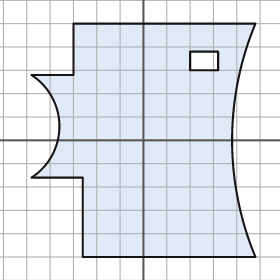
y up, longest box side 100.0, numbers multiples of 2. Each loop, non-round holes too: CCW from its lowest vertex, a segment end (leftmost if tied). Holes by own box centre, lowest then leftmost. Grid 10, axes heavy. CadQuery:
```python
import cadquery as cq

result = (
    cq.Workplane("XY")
    .moveTo(-26.0, -50.0)
    .lineTo(48.0, -50.0)
    .threePointArc((38.0, 0.0), (48.0, 50.0))
    .lineTo(-30.0, 50.0)
    .lineTo(-30.0, 28.0)
    .lineTo(-48.0, 28.0)
    .threePointArc((-36.0, 6.0), (-48.0, -16.0))
    .lineTo(-26.0, -16.0)
    .close()
    .moveTo(20.0, 30.0)
    .lineTo(32.0, 30.0)
    .lineTo(32.0, 38.0)
    .lineTo(20.0, 38.0)
    .close()
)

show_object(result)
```